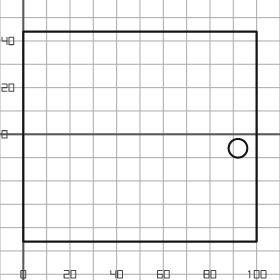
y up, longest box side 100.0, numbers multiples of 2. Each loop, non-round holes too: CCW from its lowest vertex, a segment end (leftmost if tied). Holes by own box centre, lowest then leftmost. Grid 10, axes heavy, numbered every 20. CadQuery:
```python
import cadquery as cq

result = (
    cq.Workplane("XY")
    .moveTo(0.0, -46.0)
    .lineTo(100.0, -46.0)
    .lineTo(100.0, 44.0)
    .lineTo(0.0, 44.0)
    .close()
    .moveTo(92.0, -6.0)
    .circle(4.0)
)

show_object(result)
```